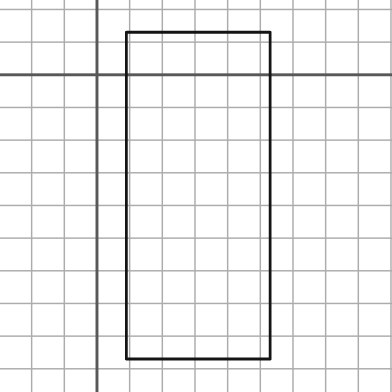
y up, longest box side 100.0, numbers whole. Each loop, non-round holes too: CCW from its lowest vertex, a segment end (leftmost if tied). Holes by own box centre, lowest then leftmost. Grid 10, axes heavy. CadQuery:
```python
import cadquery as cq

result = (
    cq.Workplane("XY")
    .moveTo(9.0, -87.0)
    .lineTo(53.0, -87.0)
    .lineTo(53.0, 13.0)
    .lineTo(9.0, 13.0)
    .close()
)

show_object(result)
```